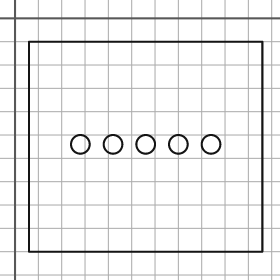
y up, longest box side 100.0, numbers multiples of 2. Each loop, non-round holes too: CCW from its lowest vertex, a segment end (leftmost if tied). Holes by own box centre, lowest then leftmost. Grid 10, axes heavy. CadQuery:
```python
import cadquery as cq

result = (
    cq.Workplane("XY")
    .moveTo(6.0, -100.0)
    .lineTo(106.0, -100.0)
    .lineTo(106.0, -10.0)
    .lineTo(6.0, -10.0)
    .close()
    .moveTo(28.0, -54.0)
    .circle(4.0)
    .moveTo(42.0, -54.0)
    .circle(4.0)
    .moveTo(56.0, -54.0)
    .circle(4.0)
    .moveTo(70.0, -54.0)
    .circle(4.0)
    .moveTo(84.0, -54.0)
    .circle(4.0)
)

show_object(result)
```